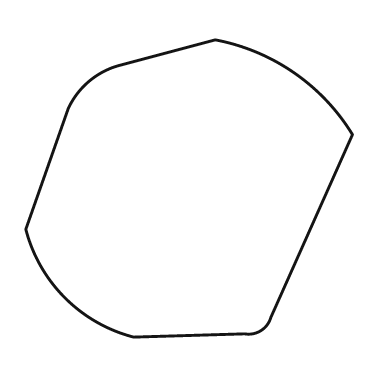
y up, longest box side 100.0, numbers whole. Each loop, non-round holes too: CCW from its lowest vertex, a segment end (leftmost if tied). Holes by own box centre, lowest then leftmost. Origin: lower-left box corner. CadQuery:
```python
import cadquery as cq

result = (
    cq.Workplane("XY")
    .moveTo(33.0, 0.0)
    .lineTo(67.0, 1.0)
    .threePointArc((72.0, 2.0), (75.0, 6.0))
    .lineTo(100.0, 62.0)
    .threePointArc((82.0, 81.0), (58.0, 91.0))
    .lineTo(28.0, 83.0)
    .threePointArc((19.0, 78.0), (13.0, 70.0))
    .lineTo(0.0, 33.0)
    .threePointArc((12.0, 12.0), (33.0, 0.0))
    .close()
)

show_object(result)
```